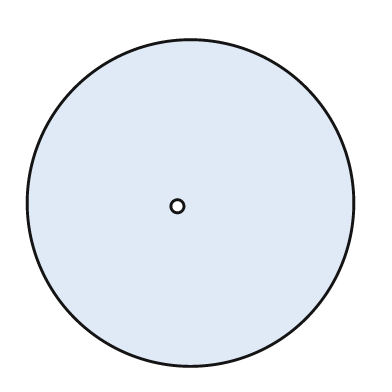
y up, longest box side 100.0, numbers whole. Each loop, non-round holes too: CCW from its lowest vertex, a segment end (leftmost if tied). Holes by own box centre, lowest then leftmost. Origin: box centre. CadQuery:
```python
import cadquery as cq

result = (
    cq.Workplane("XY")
    .moveTo(0.0, 0.0)
    .circle(50.0)
    .moveTo(-4.0, -1.0)
    .circle(2.0)
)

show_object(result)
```